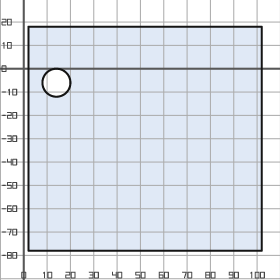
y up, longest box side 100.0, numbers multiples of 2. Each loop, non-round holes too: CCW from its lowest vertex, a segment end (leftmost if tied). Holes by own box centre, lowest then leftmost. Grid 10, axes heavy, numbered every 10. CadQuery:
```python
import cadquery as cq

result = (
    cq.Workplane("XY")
    .moveTo(2.0, -78.0)
    .lineTo(102.0, -78.0)
    .lineTo(102.0, 18.0)
    .lineTo(2.0, 18.0)
    .close()
    .moveTo(14.0, -6.0)
    .circle(6.0)
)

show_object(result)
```